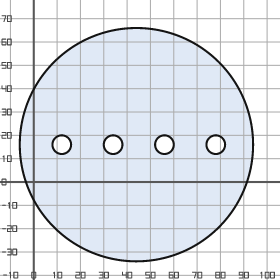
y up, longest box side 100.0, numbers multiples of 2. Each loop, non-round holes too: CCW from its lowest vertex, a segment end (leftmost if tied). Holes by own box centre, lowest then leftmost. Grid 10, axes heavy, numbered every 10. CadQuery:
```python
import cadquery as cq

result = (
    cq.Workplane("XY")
    .moveTo(44.0, 16.0)
    .circle(50.0)
    .moveTo(12.0, 16.0)
    .circle(4.0)
    .moveTo(34.0, 16.0)
    .circle(4.0)
    .moveTo(56.0, 16.0)
    .circle(4.0)
    .moveTo(78.0, 16.0)
    .circle(4.0)
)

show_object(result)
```